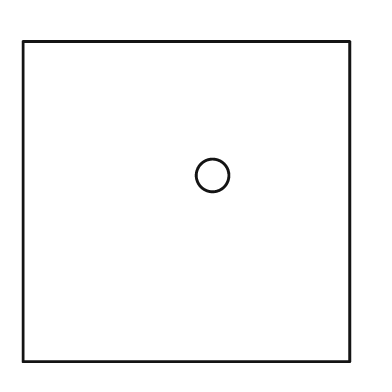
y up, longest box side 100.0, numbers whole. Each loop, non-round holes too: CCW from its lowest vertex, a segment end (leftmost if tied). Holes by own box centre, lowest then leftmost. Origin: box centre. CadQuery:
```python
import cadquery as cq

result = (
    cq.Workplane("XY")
    .moveTo(-50.0, -49.0)
    .lineTo(50.0, -49.0)
    .lineTo(50.0, 49.0)
    .lineTo(-50.0, 49.0)
    .close()
    .moveTo(8.0, 8.0)
    .circle(5.0)
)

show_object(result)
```